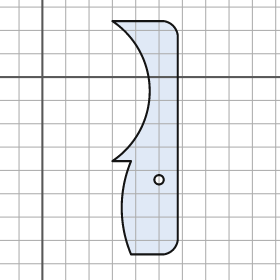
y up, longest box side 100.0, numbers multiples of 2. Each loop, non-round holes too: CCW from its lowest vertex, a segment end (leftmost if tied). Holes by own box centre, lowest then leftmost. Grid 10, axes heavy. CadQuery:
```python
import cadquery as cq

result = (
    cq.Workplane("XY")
    .moveTo(38.0, -76.0)
    .lineTo(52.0, -76.0)
    .threePointArc((56.0, -74.0), (58.0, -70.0))
    .lineTo(58.0, 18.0)
    .threePointArc((56.0, 22.0), (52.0, 24.0))
    .lineTo(30.0, 24.0)
    .threePointArc((46.0, -6.0), (30.0, -36.0))
    .lineTo(38.0, -36.0)
    .threePointArc((34.0, -56.0), (38.0, -76.0))
    .close()
    .moveTo(50.0, -44.0)
    .circle(2.0)
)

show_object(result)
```